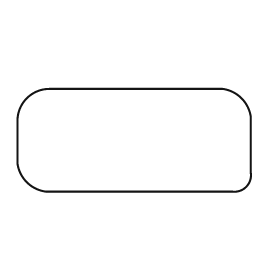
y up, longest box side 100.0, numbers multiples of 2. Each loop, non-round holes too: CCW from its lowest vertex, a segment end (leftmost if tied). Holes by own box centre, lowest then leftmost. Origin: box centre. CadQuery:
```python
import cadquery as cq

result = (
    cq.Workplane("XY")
    .moveTo(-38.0, -22.0)
    .lineTo(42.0, -22.0)
    .threePointArc((48.0, -20.0), (50.0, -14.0))
    .lineTo(50.0, 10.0)
    .threePointArc((46.0, 18.0), (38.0, 22.0))
    .lineTo(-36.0, 22.0)
    .threePointArc((-46.0, 18.0), (-50.0, 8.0))
    .lineTo(-50.0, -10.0)
    .threePointArc((-46.0, -18.0), (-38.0, -22.0))
    .close()
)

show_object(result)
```